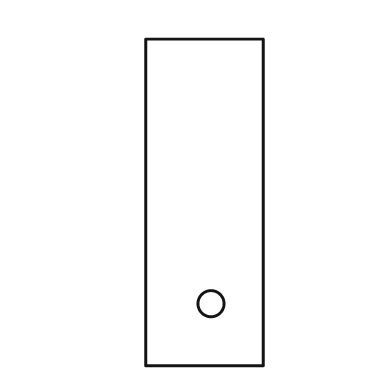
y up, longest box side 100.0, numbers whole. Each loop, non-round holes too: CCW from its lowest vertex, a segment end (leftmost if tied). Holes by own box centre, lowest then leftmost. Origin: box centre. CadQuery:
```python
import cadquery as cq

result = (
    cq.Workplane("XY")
    .moveTo(-18.0, -50.0)
    .lineTo(18.0, -50.0)
    .lineTo(18.0, 50.0)
    .lineTo(-18.0, 50.0)
    .close()
    .moveTo(2.0, -31.0)
    .circle(4.0)
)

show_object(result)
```